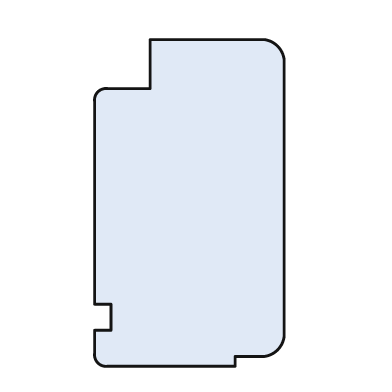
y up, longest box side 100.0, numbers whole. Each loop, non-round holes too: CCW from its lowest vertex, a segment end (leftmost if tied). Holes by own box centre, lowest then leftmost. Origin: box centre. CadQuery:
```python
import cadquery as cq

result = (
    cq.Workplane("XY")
    .moveTo(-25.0, -50.0)
    .lineTo(14.0, -50.0)
    .lineTo(14.0, -47.0)
    .lineTo(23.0, -47.0)
    .threePointArc((27.0, -45.0), (29.0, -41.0))
    .lineTo(29.0, 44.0)
    .threePointArc((27.0, 48.0), (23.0, 50.0))
    .lineTo(-12.0, 50.0)
    .lineTo(-12.0, 35.0)
    .lineTo(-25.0, 35.0)
    .threePointArc((-28.0, 34.0), (-29.0, 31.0))
    .lineTo(-29.0, -31.0)
    .lineTo(-24.0, -31.0)
    .lineTo(-24.0, -39.0)
    .lineTo(-29.0, -39.0)
    .lineTo(-29.0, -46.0)
    .threePointArc((-28.0, -49.0), (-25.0, -50.0))
    .close()
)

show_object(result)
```